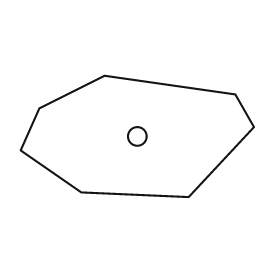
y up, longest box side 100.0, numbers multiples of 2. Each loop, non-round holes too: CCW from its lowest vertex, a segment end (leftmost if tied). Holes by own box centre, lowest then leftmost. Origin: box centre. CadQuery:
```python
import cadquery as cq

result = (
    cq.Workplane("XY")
    .moveTo(22.0, -26.0)
    .lineTo(50.0, 4.0)
    .lineTo(42.0, 18.0)
    .lineTo(-14.0, 26.0)
    .lineTo(-42.0, 12.0)
    .lineTo(-50.0, -6.0)
    .lineTo(-24.0, -24.0)
    .close()
    .moveTo(0.0, 0.0)
    .circle(4.0)
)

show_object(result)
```